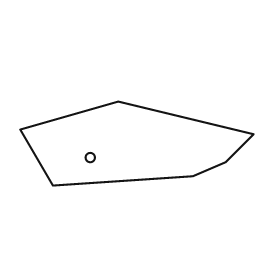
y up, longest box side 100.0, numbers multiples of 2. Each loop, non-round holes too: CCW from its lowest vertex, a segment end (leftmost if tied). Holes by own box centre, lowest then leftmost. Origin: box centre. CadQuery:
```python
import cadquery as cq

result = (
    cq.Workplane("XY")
    .moveTo(-36.0, -18.0)
    .lineTo(24.0, -14.0)
    .lineTo(38.0, -8.0)
    .lineTo(50.0, 4.0)
    .lineTo(-8.0, 18.0)
    .lineTo(-50.0, 6.0)
    .close()
    .moveTo(-20.0, -6.0)
    .circle(2.0)
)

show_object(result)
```